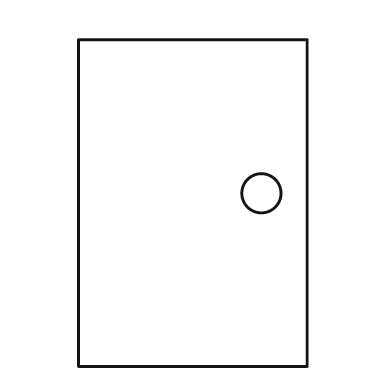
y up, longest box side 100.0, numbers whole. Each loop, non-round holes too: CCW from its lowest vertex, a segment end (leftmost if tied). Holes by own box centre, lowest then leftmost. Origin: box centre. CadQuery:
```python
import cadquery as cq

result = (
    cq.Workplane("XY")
    .moveTo(-35.0, -50.0)
    .lineTo(35.0, -50.0)
    .lineTo(35.0, 50.0)
    .lineTo(-35.0, 50.0)
    .close()
    .moveTo(21.0, 3.0)
    .circle(6.0)
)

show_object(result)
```